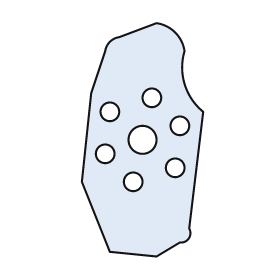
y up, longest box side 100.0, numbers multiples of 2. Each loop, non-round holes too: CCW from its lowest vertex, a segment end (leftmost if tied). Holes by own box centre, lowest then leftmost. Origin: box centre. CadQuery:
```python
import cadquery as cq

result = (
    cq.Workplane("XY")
    .moveTo(6.0, -50.0)
    .lineTo(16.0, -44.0)
    .threePointArc((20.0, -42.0), (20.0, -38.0))
    .lineTo(26.0, 12.0)
    .threePointArc((18.0, 24.0), (18.0, 38.0))
    .threePointArc((14.0, 46.0), (6.0, 50.0))
    .lineTo(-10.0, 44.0)
    .threePointArc((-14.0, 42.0), (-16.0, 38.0))
    .lineTo(-22.0, 20.0)
    .lineTo(-26.0, -18.0)
    .lineTo(-14.0, -48.0)
    .close()
    .moveTo(-4.0, -18.0)
    .circle(4.0)
    .moveTo(14.0, -12.0)
    .circle(4.0)
    .moveTo(-16.0, -6.0)
    .circle(4.0)
    .moveTo(0.0, 0.0)
    .circle(6.0)
    .moveTo(16.0, 6.0)
    .circle(4.0)
    .moveTo(-14.0, 12.0)
    .circle(4.0)
    .moveTo(4.0, 18.0)
    .circle(4.0)
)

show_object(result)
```